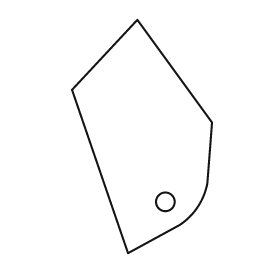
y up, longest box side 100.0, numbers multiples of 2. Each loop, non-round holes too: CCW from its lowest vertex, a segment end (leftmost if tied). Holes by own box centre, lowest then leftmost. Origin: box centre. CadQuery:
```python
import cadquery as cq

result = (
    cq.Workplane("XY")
    .moveTo(-6.0, -50.0)
    .lineTo(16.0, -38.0)
    .threePointArc((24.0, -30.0), (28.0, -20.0))
    .lineTo(30.0, 6.0)
    .lineTo(-2.0, 50.0)
    .lineTo(-30.0, 20.0)
    .close()
    .moveTo(10.0, -28.0)
    .circle(4.0)
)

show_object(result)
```